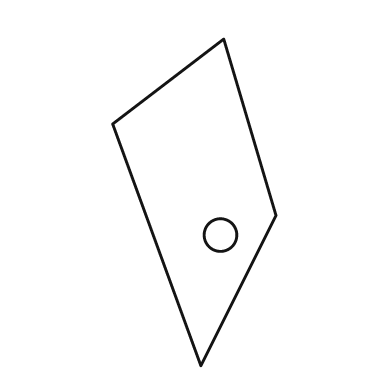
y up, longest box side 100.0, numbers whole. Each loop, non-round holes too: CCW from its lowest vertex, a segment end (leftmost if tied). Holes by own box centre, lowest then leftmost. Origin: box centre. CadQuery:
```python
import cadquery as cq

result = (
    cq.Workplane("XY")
    .moveTo(2.0, -50.0)
    .lineTo(25.0, -4.0)
    .lineTo(9.0, 50.0)
    .lineTo(-25.0, 24.0)
    .close()
    .moveTo(8.0, -10.0)
    .circle(5.0)
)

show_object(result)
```